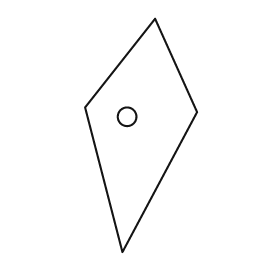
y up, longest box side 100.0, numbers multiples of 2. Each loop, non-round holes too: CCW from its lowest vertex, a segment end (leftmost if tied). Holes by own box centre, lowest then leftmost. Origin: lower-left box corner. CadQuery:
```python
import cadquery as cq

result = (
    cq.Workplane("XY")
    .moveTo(16.0, 0.0)
    .lineTo(48.0, 60.0)
    .lineTo(30.0, 100.0)
    .lineTo(0.0, 62.0)
    .close()
    .moveTo(18.0, 58.0)
    .circle(4.0)
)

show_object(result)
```